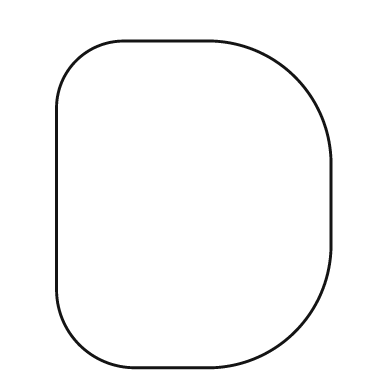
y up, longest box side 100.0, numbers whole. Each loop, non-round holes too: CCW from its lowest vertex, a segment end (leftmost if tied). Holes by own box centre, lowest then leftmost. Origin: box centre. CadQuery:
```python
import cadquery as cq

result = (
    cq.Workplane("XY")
    .moveTo(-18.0, -50.0)
    .lineTo(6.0, -50.0)
    .threePointArc((31.0, -39.0), (42.0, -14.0))
    .lineTo(42.0, 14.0)
    .threePointArc((31.0, 39.0), (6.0, 50.0))
    .lineTo(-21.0, 50.0)
    .threePointArc((-36.0, 44.0), (-42.0, 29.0))
    .lineTo(-42.0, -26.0)
    .threePointArc((-35.0, -43.0), (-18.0, -50.0))
    .close()
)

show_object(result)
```